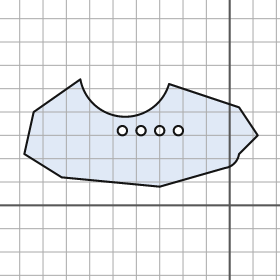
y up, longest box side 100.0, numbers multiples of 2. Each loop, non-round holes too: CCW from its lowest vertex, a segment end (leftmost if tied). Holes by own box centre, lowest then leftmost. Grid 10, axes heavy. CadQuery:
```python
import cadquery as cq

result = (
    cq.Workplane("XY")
    .moveTo(-30.0, 8.0)
    .lineTo(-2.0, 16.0)
    .threePointArc((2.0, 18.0), (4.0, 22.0))
    .lineTo(12.0, 30.0)
    .lineTo(4.0, 42.0)
    .lineTo(-26.0, 52.0)
    .threePointArc((-46.0, 38.0), (-64.0, 54.0))
    .lineTo(-84.0, 40.0)
    .lineTo(-88.0, 22.0)
    .lineTo(-72.0, 12.0)
    .close()
    .moveTo(-46.0, 32.0)
    .circle(2.0)
    .moveTo(-38.0, 32.0)
    .circle(2.0)
    .moveTo(-30.0, 32.0)
    .circle(2.0)
    .moveTo(-22.0, 32.0)
    .circle(2.0)
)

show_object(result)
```